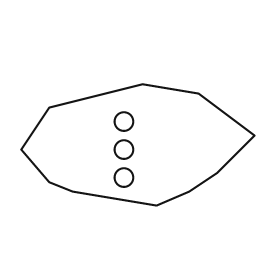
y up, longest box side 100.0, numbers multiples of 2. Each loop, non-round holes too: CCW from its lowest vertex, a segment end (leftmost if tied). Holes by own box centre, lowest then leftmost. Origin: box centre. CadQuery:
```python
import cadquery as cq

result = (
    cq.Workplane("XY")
    .moveTo(8.0, -26.0)
    .lineTo(22.0, -20.0)
    .lineTo(34.0, -12.0)
    .lineTo(50.0, 4.0)
    .lineTo(26.0, 22.0)
    .lineTo(2.0, 26.0)
    .lineTo(-38.0, 16.0)
    .lineTo(-50.0, -2.0)
    .lineTo(-38.0, -16.0)
    .lineTo(-28.0, -20.0)
    .close()
    .moveTo(-6.0, -14.0)
    .circle(4.0)
    .moveTo(-6.0, -2.0)
    .circle(4.0)
    .moveTo(-6.0, 10.0)
    .circle(4.0)
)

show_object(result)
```